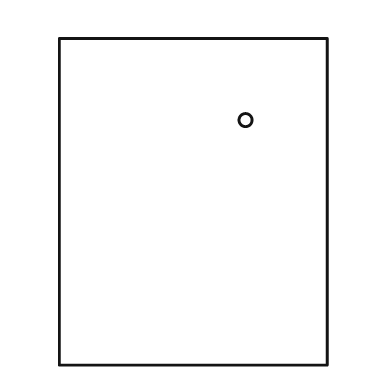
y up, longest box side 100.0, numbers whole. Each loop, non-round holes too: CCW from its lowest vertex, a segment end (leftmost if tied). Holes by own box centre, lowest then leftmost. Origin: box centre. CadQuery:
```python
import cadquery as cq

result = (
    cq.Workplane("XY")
    .moveTo(-41.0, -50.0)
    .lineTo(41.0, -50.0)
    .lineTo(41.0, 50.0)
    .lineTo(-41.0, 50.0)
    .close()
    .moveTo(16.0, 25.0)
    .circle(2.0)
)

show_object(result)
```